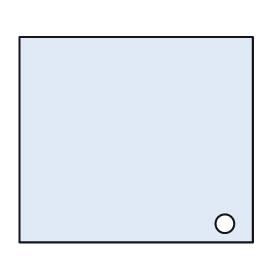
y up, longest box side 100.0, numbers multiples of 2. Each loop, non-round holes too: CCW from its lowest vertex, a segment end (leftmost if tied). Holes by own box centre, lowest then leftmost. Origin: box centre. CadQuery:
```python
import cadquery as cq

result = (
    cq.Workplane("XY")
    .moveTo(-50.0, -44.0)
    .lineTo(50.0, -44.0)
    .lineTo(50.0, 44.0)
    .lineTo(-50.0, 44.0)
    .close()
    .moveTo(38.0, -36.0)
    .circle(4.0)
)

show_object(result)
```